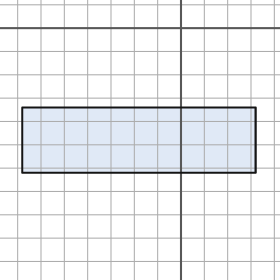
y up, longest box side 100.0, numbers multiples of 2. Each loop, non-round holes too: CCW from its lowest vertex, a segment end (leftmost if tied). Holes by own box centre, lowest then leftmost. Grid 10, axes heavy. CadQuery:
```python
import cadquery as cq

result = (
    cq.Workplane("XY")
    .moveTo(-68.0, -62.0)
    .lineTo(32.0, -62.0)
    .lineTo(32.0, -34.0)
    .lineTo(-68.0, -34.0)
    .close()
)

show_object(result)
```